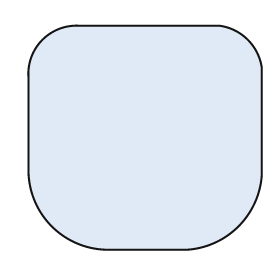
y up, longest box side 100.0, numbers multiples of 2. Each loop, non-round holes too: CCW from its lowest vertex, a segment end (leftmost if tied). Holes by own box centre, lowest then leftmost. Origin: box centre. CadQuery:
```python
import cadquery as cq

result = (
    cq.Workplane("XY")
    .moveTo(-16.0, -48.0)
    .lineTo(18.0, -48.0)
    .threePointArc((40.0, -38.0), (50.0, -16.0))
    .lineTo(50.0, 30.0)
    .threePointArc((44.0, 42.0), (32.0, 48.0))
    .lineTo(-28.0, 48.0)
    .threePointArc((-44.0, 42.0), (-50.0, 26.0))
    .lineTo(-50.0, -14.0)
    .threePointArc((-40.0, -38.0), (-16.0, -48.0))
    .close()
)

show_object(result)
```